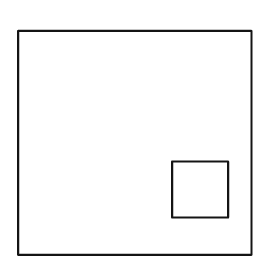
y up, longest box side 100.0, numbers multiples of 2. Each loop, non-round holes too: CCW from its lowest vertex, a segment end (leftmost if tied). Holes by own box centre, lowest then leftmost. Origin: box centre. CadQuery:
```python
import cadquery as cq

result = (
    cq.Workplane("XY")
    .moveTo(-50.0, -48.0)
    .lineTo(50.0, -48.0)
    .lineTo(50.0, 48.0)
    .lineTo(-50.0, 48.0)
    .close()
    .moveTo(16.0, -32.0)
    .lineTo(40.0, -32.0)
    .lineTo(40.0, -8.0)
    .lineTo(16.0, -8.0)
    .close()
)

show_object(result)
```